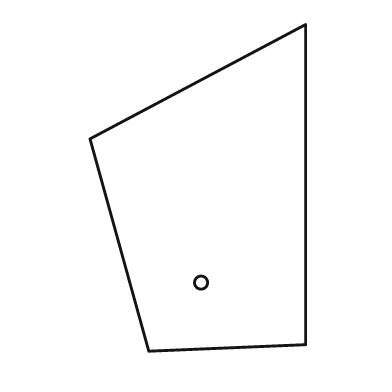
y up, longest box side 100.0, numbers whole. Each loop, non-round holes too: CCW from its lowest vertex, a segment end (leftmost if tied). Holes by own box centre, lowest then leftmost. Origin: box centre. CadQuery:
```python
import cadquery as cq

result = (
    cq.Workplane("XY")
    .moveTo(-15.0, -50.0)
    .lineTo(33.0, -48.0)
    .lineTo(33.0, 50.0)
    .lineTo(-33.0, 15.0)
    .close()
    .moveTo(1.0, -29.0)
    .circle(2.0)
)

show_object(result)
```